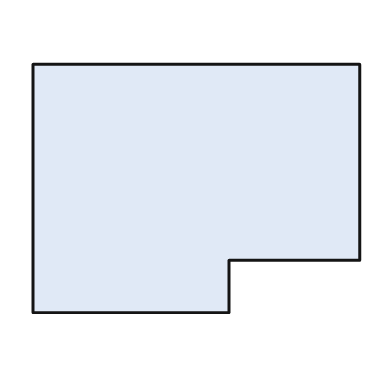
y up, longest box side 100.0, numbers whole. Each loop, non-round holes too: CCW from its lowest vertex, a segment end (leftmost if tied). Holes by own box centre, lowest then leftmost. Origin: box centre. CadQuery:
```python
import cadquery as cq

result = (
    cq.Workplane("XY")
    .moveTo(-50.0, -38.0)
    .lineTo(10.0, -38.0)
    .lineTo(10.0, -22.0)
    .lineTo(50.0, -22.0)
    .lineTo(50.0, 38.0)
    .lineTo(-50.0, 38.0)
    .close()
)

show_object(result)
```